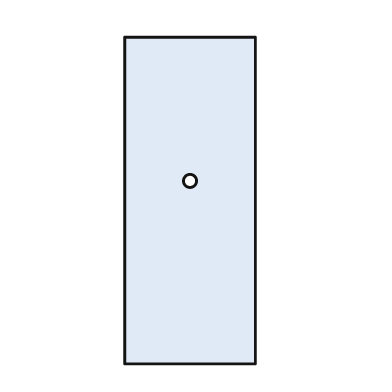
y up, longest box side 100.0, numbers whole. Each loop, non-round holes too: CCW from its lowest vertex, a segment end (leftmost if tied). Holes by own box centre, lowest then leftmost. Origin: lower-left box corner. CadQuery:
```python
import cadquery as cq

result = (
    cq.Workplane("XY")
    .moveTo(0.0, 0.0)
    .lineTo(40.0, 0.0)
    .lineTo(40.0, 100.0)
    .lineTo(0.0, 100.0)
    .close()
    .moveTo(20.0, 56.0)
    .circle(2.0)
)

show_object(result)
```